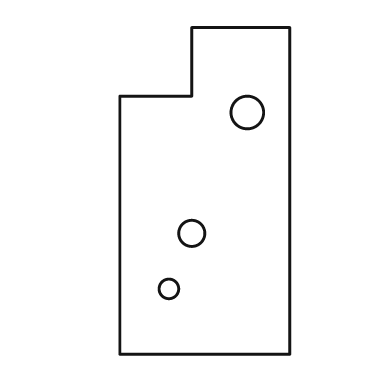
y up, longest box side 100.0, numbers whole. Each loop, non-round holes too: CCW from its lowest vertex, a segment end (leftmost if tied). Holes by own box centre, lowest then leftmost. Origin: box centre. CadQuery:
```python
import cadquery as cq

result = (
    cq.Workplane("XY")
    .moveTo(-26.0, -50.0)
    .lineTo(26.0, -50.0)
    .lineTo(26.0, 50.0)
    .lineTo(-4.0, 50.0)
    .lineTo(-4.0, 29.0)
    .lineTo(-26.0, 29.0)
    .close()
    .moveTo(-11.0, -30.0)
    .circle(3.0)
    .moveTo(-4.0, -13.0)
    .circle(4.0)
    .moveTo(13.0, 24.0)
    .circle(5.0)
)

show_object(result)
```